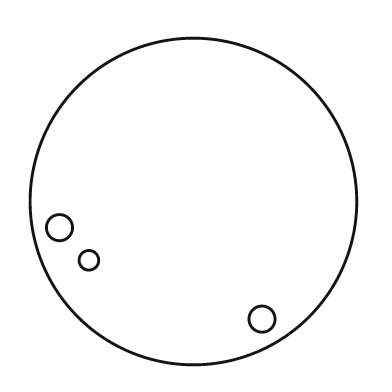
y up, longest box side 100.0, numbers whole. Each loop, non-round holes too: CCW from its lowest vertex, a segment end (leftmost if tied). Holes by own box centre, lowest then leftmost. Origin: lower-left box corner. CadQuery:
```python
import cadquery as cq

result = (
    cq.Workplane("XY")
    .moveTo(50.0, 50.0)
    .circle(50.0)
    .moveTo(71.0, 14.0)
    .circle(4.0)
    .moveTo(18.0, 32.0)
    .circle(3.0)
    .moveTo(9.0, 42.0)
    .circle(4.0)
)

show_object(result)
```